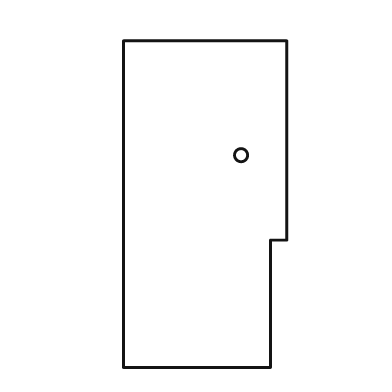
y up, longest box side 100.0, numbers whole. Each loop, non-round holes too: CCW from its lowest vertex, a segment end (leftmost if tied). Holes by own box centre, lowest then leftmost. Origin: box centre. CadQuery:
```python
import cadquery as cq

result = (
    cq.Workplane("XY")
    .moveTo(-25.0, -50.0)
    .lineTo(20.0, -50.0)
    .lineTo(20.0, -11.0)
    .lineTo(25.0, -11.0)
    .lineTo(25.0, 50.0)
    .lineTo(-25.0, 50.0)
    .close()
    .moveTo(11.0, 15.0)
    .circle(2.0)
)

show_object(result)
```